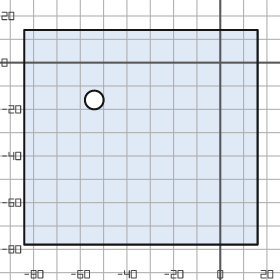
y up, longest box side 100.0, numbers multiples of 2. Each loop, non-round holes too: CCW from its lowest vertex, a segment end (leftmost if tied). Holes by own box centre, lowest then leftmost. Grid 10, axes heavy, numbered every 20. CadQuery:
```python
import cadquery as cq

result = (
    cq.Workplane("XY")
    .moveTo(-84.0, -78.0)
    .lineTo(16.0, -78.0)
    .lineTo(16.0, 14.0)
    .lineTo(-84.0, 14.0)
    .close()
    .moveTo(-54.0, -16.0)
    .circle(4.0)
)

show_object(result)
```